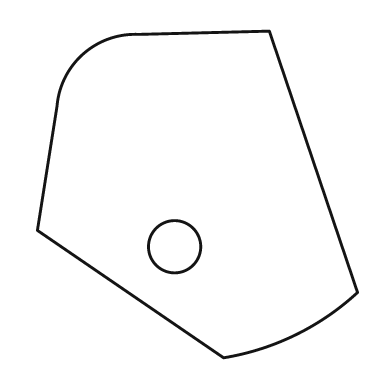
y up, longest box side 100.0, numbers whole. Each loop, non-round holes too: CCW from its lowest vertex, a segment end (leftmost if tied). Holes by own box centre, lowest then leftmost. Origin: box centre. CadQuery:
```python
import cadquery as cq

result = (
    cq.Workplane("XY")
    .moveTo(8.0, -50.0)
    .threePointArc((30.0, -43.0), (49.0, -30.0))
    .lineTo(22.0, 50.0)
    .lineTo(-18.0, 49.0)
    .threePointArc((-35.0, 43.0), (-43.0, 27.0))
    .lineTo(-49.0, -11.0)
    .close()
    .moveTo(-7.0, -16.0)
    .circle(8.0)
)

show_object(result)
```